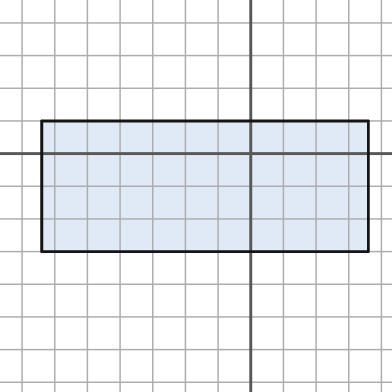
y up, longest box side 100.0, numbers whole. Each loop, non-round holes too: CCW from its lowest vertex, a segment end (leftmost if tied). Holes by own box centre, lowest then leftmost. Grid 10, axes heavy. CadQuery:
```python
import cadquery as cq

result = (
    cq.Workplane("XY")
    .moveTo(-64.0, -30.0)
    .lineTo(36.0, -30.0)
    .lineTo(36.0, 10.0)
    .lineTo(-64.0, 10.0)
    .close()
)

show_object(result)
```